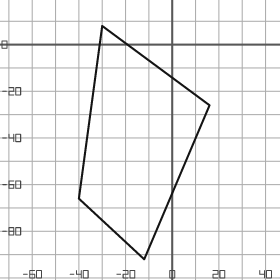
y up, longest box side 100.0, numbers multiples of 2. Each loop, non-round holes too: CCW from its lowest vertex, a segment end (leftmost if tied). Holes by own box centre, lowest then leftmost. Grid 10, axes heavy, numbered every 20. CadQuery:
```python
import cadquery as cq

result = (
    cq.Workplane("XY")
    .moveTo(-12.0, -92.0)
    .lineTo(16.0, -26.0)
    .lineTo(-30.0, 8.0)
    .lineTo(-40.0, -66.0)
    .close()
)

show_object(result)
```